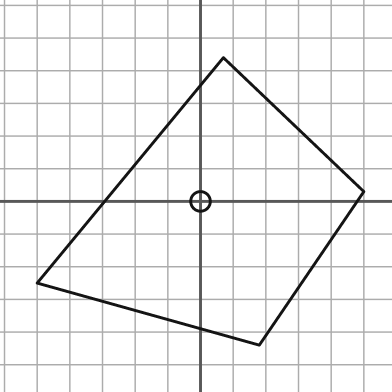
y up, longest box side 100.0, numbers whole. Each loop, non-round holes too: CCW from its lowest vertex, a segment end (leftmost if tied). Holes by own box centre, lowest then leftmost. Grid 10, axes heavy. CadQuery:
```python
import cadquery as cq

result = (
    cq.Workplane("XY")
    .moveTo(18.0, -44.0)
    .lineTo(50.0, 3.0)
    .lineTo(7.0, 44.0)
    .lineTo(-50.0, -25.0)
    .close()
    .moveTo(0.0, 0.0)
    .circle(3.0)
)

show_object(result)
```